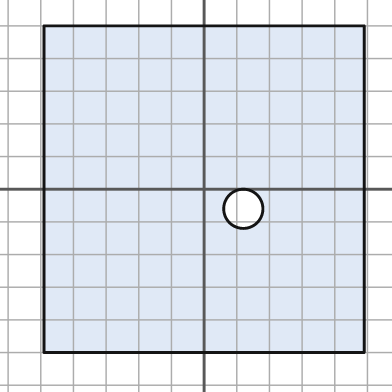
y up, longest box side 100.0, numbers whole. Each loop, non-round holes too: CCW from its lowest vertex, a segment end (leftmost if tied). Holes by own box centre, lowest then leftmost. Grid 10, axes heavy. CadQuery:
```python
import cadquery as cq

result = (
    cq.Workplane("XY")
    .moveTo(-49.0, -50.0)
    .lineTo(49.0, -50.0)
    .lineTo(49.0, 50.0)
    .lineTo(-49.0, 50.0)
    .close()
    .moveTo(12.0, -6.0)
    .circle(6.0)
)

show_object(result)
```